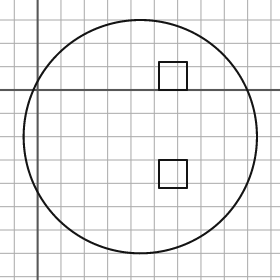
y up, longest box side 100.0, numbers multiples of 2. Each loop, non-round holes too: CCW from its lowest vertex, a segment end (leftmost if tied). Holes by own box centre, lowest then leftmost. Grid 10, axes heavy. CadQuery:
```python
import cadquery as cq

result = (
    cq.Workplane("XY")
    .moveTo(44.0, -20.0)
    .circle(50.0)
    .moveTo(52.0, -42.0)
    .lineTo(64.0, -42.0)
    .lineTo(64.0, -30.0)
    .lineTo(52.0, -30.0)
    .close()
    .moveTo(52.0, 0.0)
    .lineTo(64.0, 0.0)
    .lineTo(64.0, 12.0)
    .lineTo(52.0, 12.0)
    .close()
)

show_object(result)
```